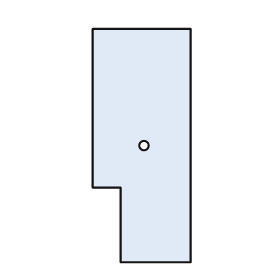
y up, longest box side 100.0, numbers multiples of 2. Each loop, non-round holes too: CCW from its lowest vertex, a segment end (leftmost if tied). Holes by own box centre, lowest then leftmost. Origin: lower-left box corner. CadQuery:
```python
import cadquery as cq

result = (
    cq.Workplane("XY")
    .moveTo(12.0, 0.0)
    .lineTo(42.0, 0.0)
    .lineTo(42.0, 100.0)
    .lineTo(0.0, 100.0)
    .lineTo(0.0, 32.0)
    .lineTo(12.0, 32.0)
    .close()
    .moveTo(22.0, 50.0)
    .circle(2.0)
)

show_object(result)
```